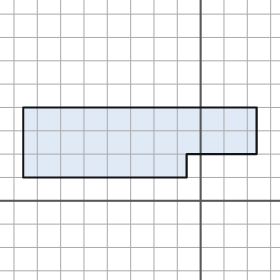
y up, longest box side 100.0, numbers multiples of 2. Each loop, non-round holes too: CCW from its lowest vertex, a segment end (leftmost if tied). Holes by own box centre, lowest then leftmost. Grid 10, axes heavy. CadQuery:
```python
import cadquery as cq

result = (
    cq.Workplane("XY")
    .moveTo(-76.0, 10.0)
    .lineTo(-6.0, 10.0)
    .lineTo(-6.0, 20.0)
    .lineTo(24.0, 20.0)
    .lineTo(24.0, 40.0)
    .lineTo(-76.0, 40.0)
    .close()
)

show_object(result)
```